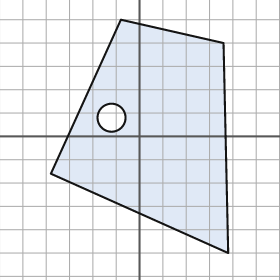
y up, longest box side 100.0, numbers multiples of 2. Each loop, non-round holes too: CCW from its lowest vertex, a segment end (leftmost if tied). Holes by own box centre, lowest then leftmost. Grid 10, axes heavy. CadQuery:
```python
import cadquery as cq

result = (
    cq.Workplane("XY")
    .moveTo(38.0, -50.0)
    .lineTo(36.0, 40.0)
    .lineTo(-8.0, 50.0)
    .lineTo(-38.0, -16.0)
    .close()
    .moveTo(-12.0, 8.0)
    .circle(6.0)
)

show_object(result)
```